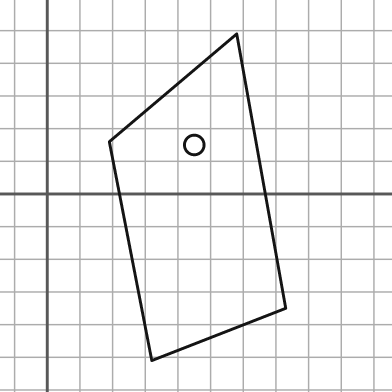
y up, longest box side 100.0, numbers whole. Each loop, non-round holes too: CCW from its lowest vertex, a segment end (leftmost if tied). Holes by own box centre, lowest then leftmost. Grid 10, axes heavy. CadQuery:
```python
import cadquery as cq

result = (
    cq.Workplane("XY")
    .moveTo(32.0, -51.0)
    .lineTo(73.0, -35.0)
    .lineTo(58.0, 49.0)
    .lineTo(19.0, 16.0)
    .close()
    .moveTo(45.0, 15.0)
    .circle(3.0)
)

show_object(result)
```